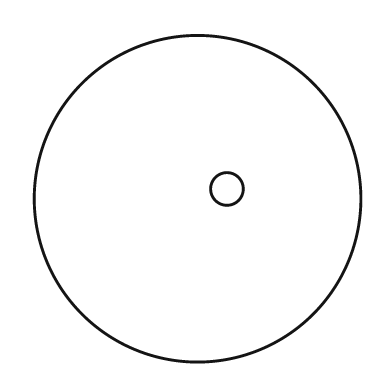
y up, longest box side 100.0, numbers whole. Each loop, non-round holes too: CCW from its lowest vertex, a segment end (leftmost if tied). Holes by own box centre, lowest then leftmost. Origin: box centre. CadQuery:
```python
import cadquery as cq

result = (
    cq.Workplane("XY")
    .moveTo(0.0, 0.0)
    .circle(50.0)
    .moveTo(9.0, 3.0)
    .circle(5.0)
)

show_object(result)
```